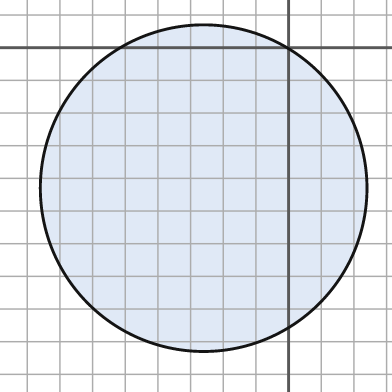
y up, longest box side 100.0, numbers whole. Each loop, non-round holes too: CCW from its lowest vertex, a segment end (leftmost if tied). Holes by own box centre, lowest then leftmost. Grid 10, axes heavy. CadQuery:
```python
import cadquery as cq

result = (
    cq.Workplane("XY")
    .moveTo(-26.0, -43.0)
    .circle(50.0)
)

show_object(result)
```